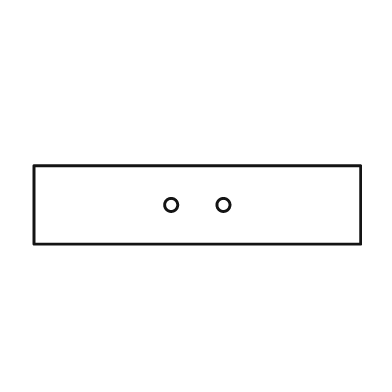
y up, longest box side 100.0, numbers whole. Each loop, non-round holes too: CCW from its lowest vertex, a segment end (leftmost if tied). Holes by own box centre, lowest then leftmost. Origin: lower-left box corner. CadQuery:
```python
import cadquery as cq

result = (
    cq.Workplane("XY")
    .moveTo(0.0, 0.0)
    .lineTo(100.0, 0.0)
    .lineTo(100.0, 24.0)
    .lineTo(0.0, 24.0)
    .close()
    .moveTo(42.0, 12.0)
    .circle(2.0)
    .moveTo(58.0, 12.0)
    .circle(2.0)
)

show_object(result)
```